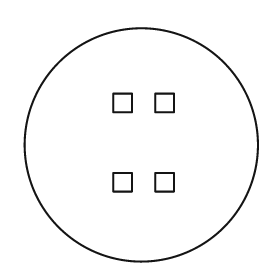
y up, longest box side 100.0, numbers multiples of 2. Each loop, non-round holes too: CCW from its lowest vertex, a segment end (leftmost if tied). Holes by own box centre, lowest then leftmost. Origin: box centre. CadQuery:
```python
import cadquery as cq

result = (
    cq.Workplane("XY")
    .moveTo(0.0, 0.0)
    .circle(50.0)
    .moveTo(-12.0, -20.0)
    .lineTo(-4.0, -20.0)
    .lineTo(-4.0, -12.0)
    .lineTo(-12.0, -12.0)
    .close()
    .moveTo(6.0, -20.0)
    .lineTo(14.0, -20.0)
    .lineTo(14.0, -12.0)
    .lineTo(6.0, -12.0)
    .close()
    .moveTo(-12.0, 14.0)
    .lineTo(-4.0, 14.0)
    .lineTo(-4.0, 22.0)
    .lineTo(-12.0, 22.0)
    .close()
    .moveTo(6.0, 14.0)
    .lineTo(14.0, 14.0)
    .lineTo(14.0, 22.0)
    .lineTo(6.0, 22.0)
    .close()
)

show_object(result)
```